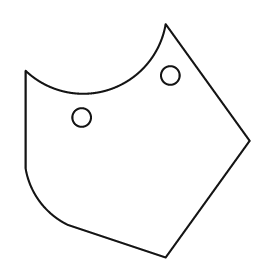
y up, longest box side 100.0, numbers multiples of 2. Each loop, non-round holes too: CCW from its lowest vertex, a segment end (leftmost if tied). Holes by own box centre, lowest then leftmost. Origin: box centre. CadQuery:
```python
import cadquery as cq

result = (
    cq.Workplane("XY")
    .moveTo(12.0, -50.0)
    .lineTo(48.0, 0.0)
    .lineTo(12.0, 50.0)
    .threePointArc((-12.0, 22.0), (-48.0, 30.0))
    .lineTo(-48.0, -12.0)
    .threePointArc((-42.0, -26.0), (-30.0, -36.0))
    .close()
    .moveTo(-24.0, 10.0)
    .circle(4.0)
    .moveTo(14.0, 28.0)
    .circle(4.0)
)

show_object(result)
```